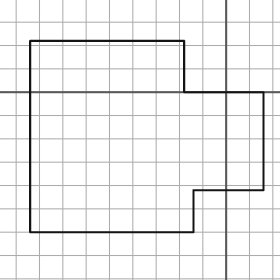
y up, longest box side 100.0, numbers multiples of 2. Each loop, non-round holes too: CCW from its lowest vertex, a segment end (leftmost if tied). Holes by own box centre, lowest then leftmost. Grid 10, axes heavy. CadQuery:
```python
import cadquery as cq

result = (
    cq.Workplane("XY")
    .moveTo(-84.0, -60.0)
    .lineTo(-14.0, -60.0)
    .lineTo(-14.0, -42.0)
    .lineTo(16.0, -42.0)
    .lineTo(16.0, 0.0)
    .lineTo(-18.0, 0.0)
    .lineTo(-18.0, 22.0)
    .lineTo(-84.0, 22.0)
    .close()
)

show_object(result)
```